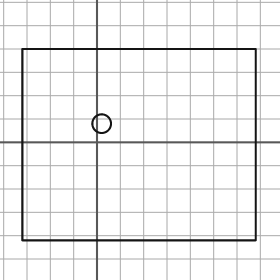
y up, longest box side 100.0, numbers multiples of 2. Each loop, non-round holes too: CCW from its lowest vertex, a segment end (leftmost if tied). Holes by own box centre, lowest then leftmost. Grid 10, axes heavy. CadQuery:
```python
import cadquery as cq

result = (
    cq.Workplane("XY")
    .moveTo(-32.0, -42.0)
    .lineTo(68.0, -42.0)
    .lineTo(68.0, 40.0)
    .lineTo(-32.0, 40.0)
    .close()
    .moveTo(2.0, 8.0)
    .circle(4.0)
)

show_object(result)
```